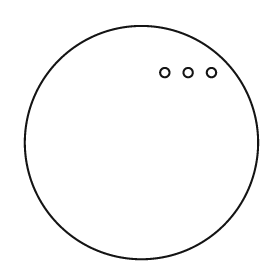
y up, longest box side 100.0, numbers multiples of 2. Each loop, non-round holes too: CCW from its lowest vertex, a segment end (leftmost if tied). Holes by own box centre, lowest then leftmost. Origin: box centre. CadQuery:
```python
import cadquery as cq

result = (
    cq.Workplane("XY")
    .moveTo(0.0, 0.0)
    .circle(50.0)
    .moveTo(10.0, 30.0)
    .circle(2.0)
    .moveTo(20.0, 30.0)
    .circle(2.0)
    .moveTo(30.0, 30.0)
    .circle(2.0)
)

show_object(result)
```